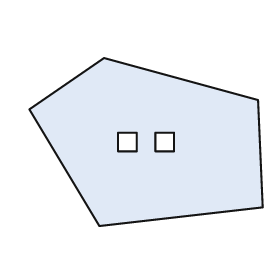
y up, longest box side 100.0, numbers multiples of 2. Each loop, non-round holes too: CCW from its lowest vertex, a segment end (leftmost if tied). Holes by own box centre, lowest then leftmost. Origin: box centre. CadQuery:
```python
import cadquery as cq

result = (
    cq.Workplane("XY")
    .moveTo(-20.0, -36.0)
    .lineTo(50.0, -28.0)
    .lineTo(48.0, 18.0)
    .lineTo(-18.0, 36.0)
    .lineTo(-50.0, 14.0)
    .close()
    .moveTo(-12.0, -4.0)
    .lineTo(-4.0, -4.0)
    .lineTo(-4.0, 4.0)
    .lineTo(-12.0, 4.0)
    .close()
    .moveTo(4.0, -4.0)
    .lineTo(12.0, -4.0)
    .lineTo(12.0, 4.0)
    .lineTo(4.0, 4.0)
    .close()
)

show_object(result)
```